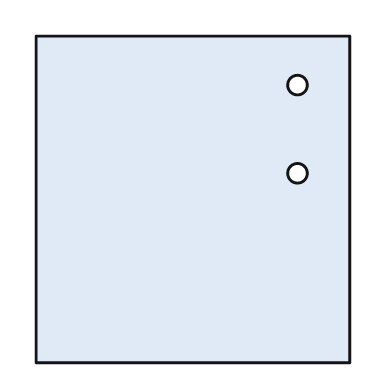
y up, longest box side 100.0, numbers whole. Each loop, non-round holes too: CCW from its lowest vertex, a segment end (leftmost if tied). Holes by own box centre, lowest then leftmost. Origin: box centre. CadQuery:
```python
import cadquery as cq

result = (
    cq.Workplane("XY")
    .moveTo(-48.0, -50.0)
    .lineTo(48.0, -50.0)
    .lineTo(48.0, 50.0)
    .lineTo(-48.0, 50.0)
    .close()
    .moveTo(32.0, 8.0)
    .circle(3.0)
    .moveTo(32.0, 35.0)
    .circle(3.0)
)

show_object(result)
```